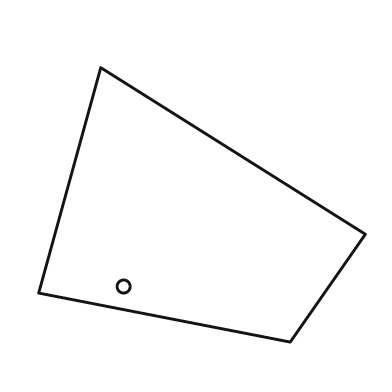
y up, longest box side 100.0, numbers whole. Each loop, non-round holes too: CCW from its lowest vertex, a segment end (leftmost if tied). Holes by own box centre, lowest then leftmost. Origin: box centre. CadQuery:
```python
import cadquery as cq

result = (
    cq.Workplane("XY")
    .moveTo(27.0, -42.0)
    .lineTo(50.0, -9.0)
    .lineTo(-31.0, 42.0)
    .lineTo(-50.0, -27.0)
    .close()
    .moveTo(-24.0, -25.0)
    .circle(2.0)
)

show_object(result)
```